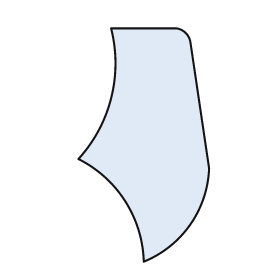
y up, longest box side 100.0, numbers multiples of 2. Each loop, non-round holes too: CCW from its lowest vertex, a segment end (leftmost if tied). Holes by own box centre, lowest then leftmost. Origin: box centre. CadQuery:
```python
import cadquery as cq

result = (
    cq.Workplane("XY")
    .moveTo(0.0, -50.0)
    .threePointArc((20.0, -34.0), (28.0, -10.0))
    .lineTo(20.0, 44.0)
    .threePointArc((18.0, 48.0), (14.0, 50.0))
    .lineTo(-14.0, 50.0)
    .threePointArc((-14.0, 20.0), (-28.0, -6.0))
    .threePointArc((-8.0, -24.0), (0.0, -50.0))
    .close()
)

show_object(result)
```